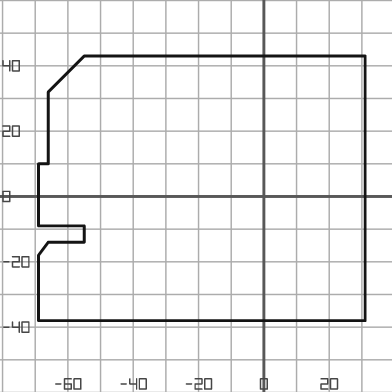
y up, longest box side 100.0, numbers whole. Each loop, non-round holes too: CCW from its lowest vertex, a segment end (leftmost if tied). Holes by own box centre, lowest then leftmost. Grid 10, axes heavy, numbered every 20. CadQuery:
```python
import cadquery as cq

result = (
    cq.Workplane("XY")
    .moveTo(-69.0, -38.0)
    .lineTo(31.0, -38.0)
    .lineTo(31.0, 43.0)
    .lineTo(-55.0, 43.0)
    .lineTo(-66.0, 32.0)
    .lineTo(-66.0, 10.0)
    .lineTo(-69.0, 10.0)
    .lineTo(-69.0, -9.0)
    .lineTo(-55.0, -9.0)
    .lineTo(-55.0, -14.0)
    .lineTo(-66.0, -14.0)
    .lineTo(-69.0, -18.0)
    .close()
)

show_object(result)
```